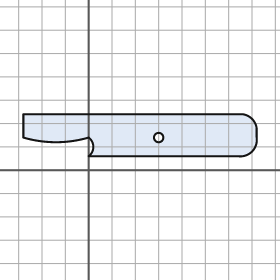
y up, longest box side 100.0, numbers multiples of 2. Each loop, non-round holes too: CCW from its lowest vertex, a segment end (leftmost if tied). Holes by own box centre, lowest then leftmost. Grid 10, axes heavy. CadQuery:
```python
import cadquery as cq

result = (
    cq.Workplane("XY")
    .moveTo(0.0, 6.0)
    .lineTo(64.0, 6.0)
    .threePointArc((70.0, 8.0), (72.0, 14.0))
    .lineTo(72.0, 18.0)
    .threePointArc((70.0, 22.0), (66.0, 24.0))
    .lineTo(-28.0, 24.0)
    .lineTo(-28.0, 14.0)
    .threePointArc((-14.0, 12.0), (0.0, 14.0))
    .threePointArc((2.0, 10.0), (0.0, 6.0))
    .close()
    .moveTo(30.0, 14.0)
    .circle(2.0)
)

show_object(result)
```